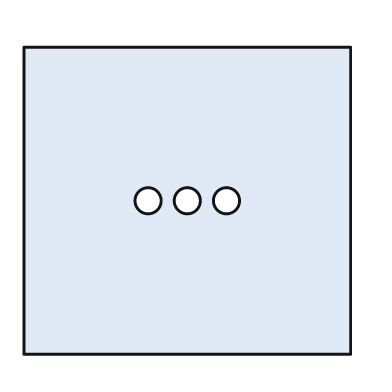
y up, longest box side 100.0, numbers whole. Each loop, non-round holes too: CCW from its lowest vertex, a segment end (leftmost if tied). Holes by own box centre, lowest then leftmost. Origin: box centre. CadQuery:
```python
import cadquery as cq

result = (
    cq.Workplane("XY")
    .moveTo(-50.0, -47.0)
    .lineTo(50.0, -47.0)
    .lineTo(50.0, 47.0)
    .lineTo(-50.0, 47.0)
    .close()
    .moveTo(-12.0, 0.0)
    .circle(4.0)
    .moveTo(0.0, 0.0)
    .circle(4.0)
    .moveTo(12.0, 0.0)
    .circle(4.0)
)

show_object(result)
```